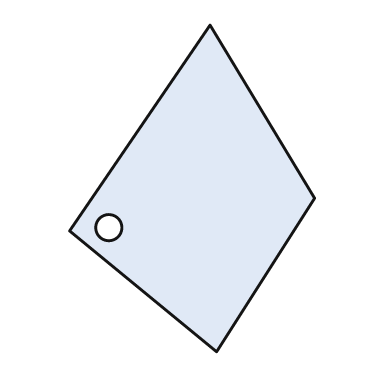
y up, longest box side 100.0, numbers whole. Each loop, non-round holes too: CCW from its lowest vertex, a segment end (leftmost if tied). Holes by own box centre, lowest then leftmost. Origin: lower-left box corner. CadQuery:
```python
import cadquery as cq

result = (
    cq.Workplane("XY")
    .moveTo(45.0, 0.0)
    .lineTo(75.0, 47.0)
    .lineTo(43.0, 100.0)
    .lineTo(0.0, 37.0)
    .close()
    .moveTo(12.0, 38.0)
    .circle(4.0)
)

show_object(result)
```